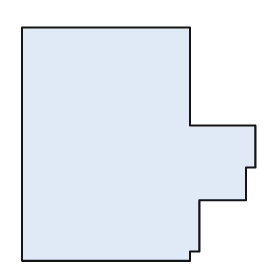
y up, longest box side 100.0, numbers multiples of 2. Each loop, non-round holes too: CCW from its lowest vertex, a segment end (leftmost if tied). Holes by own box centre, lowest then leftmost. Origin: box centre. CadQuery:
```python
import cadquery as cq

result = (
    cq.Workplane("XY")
    .moveTo(-50.0, -50.0)
    .lineTo(22.0, -50.0)
    .lineTo(22.0, -46.0)
    .lineTo(26.0, -46.0)
    .lineTo(26.0, -24.0)
    .lineTo(46.0, -24.0)
    .lineTo(46.0, -10.0)
    .lineTo(50.0, -10.0)
    .lineTo(50.0, 8.0)
    .lineTo(22.0, 8.0)
    .lineTo(22.0, 50.0)
    .lineTo(-50.0, 50.0)
    .close()
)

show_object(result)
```